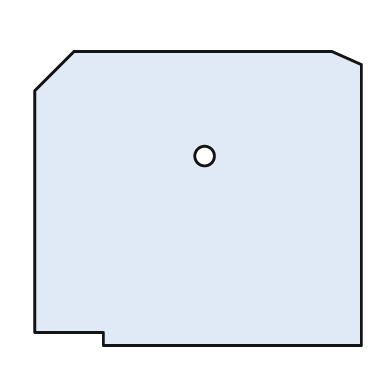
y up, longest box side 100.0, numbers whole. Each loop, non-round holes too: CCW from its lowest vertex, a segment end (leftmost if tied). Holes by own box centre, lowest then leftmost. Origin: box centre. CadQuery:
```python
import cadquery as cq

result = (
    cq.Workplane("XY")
    .moveTo(-29.0, -45.0)
    .lineTo(50.0, -45.0)
    .lineTo(50.0, 41.0)
    .lineTo(41.0, 45.0)
    .lineTo(-38.0, 45.0)
    .lineTo(-50.0, 33.0)
    .lineTo(-50.0, -41.0)
    .lineTo(-29.0, -41.0)
    .close()
    .moveTo(2.0, 13.0)
    .circle(3.0)
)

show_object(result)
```